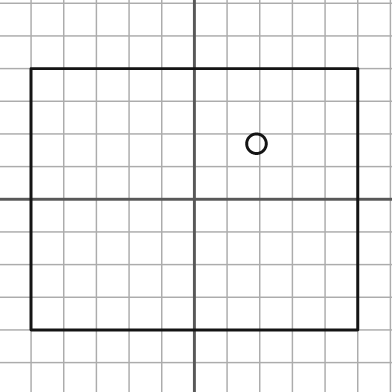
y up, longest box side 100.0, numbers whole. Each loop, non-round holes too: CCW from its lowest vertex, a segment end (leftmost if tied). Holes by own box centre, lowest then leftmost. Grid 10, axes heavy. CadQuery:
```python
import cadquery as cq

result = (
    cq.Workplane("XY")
    .moveTo(-50.0, -40.0)
    .lineTo(50.0, -40.0)
    .lineTo(50.0, 40.0)
    .lineTo(-50.0, 40.0)
    .close()
    .moveTo(19.0, 17.0)
    .circle(3.0)
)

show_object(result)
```